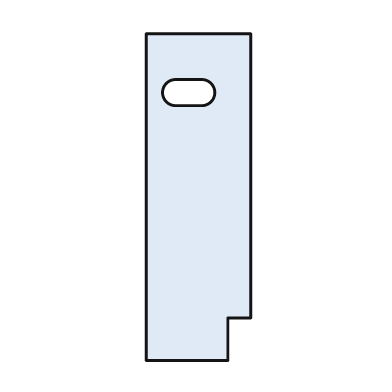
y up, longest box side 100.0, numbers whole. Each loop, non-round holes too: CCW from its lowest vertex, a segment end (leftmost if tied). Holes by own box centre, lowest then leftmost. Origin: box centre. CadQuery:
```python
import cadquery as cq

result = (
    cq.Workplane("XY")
    .moveTo(-16.0, -50.0)
    .lineTo(9.0, -50.0)
    .lineTo(9.0, -37.0)
    .lineTo(16.0, -37.0)
    .lineTo(16.0, 50.0)
    .lineTo(-16.0, 50.0)
    .close()
    .moveTo(-7.0, 28.0)
    .lineTo(1.0, 28.0)
    .threePointArc((5.0, 32.0), (1.0, 36.0))
    .lineTo(-7.0, 36.0)
    .threePointArc((-11.0, 32.0), (-7.0, 28.0))
    .close()
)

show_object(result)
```